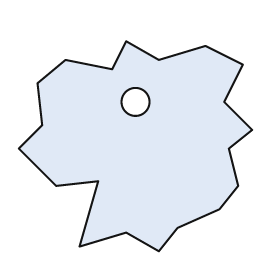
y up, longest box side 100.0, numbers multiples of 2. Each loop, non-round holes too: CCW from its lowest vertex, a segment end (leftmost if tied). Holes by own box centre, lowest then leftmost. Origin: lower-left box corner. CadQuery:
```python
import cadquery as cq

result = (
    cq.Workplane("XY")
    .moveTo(60.0, 0.0)
    .lineTo(68.0, 10.0)
    .lineTo(86.0, 18.0)
    .lineTo(94.0, 28.0)
    .lineTo(90.0, 44.0)
    .lineTo(100.0, 52.0)
    .lineTo(88.0, 64.0)
    .lineTo(96.0, 80.0)
    .lineTo(80.0, 88.0)
    .lineTo(60.0, 82.0)
    .lineTo(46.0, 90.0)
    .lineTo(40.0, 78.0)
    .lineTo(20.0, 82.0)
    .lineTo(8.0, 72.0)
    .lineTo(10.0, 54.0)
    .lineTo(0.0, 44.0)
    .lineTo(16.0, 28.0)
    .lineTo(34.0, 30.0)
    .lineTo(26.0, 2.0)
    .lineTo(46.0, 8.0)
    .close()
    .moveTo(50.0, 64.0)
    .circle(6.0)
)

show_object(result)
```